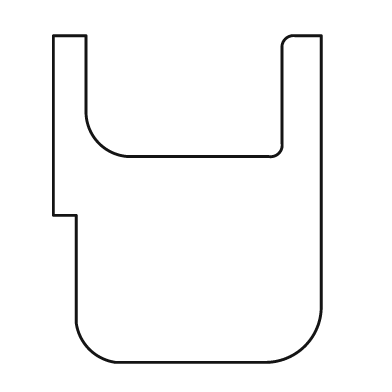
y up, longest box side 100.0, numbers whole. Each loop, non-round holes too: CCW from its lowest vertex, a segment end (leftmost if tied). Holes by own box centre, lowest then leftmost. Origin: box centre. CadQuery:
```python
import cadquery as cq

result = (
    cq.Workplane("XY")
    .moveTo(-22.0, -50.0)
    .lineTo(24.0, -50.0)
    .threePointArc((36.0, -45.0), (41.0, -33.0))
    .lineTo(41.0, 50.0)
    .lineTo(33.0, 50.0)
    .threePointArc((30.0, 49.0), (29.0, 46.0))
    .lineTo(29.0, 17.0)
    .threePointArc((28.0, 14.0), (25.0, 13.0))
    .lineTo(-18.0, 13.0)
    .threePointArc((-27.0, 17.0), (-31.0, 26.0))
    .lineTo(-31.0, 50.0)
    .lineTo(-41.0, 50.0)
    .lineTo(-41.0, -5.0)
    .lineTo(-34.0, -5.0)
    .lineTo(-34.0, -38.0)
    .threePointArc((-30.0, -46.0), (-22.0, -50.0))
    .close()
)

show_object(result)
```